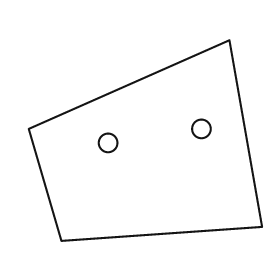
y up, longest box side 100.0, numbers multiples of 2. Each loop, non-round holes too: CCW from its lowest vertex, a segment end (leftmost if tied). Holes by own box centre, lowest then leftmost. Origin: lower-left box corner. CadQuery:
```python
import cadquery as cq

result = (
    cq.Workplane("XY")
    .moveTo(14.0, 0.0)
    .lineTo(100.0, 6.0)
    .lineTo(86.0, 86.0)
    .lineTo(0.0, 48.0)
    .close()
    .moveTo(34.0, 42.0)
    .circle(4.0)
    .moveTo(74.0, 48.0)
    .circle(4.0)
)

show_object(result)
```